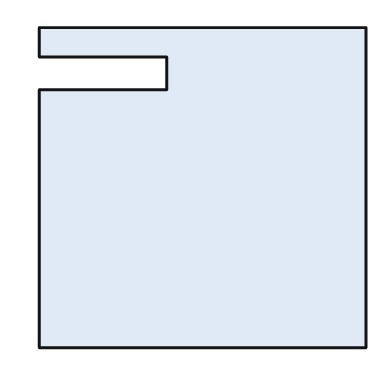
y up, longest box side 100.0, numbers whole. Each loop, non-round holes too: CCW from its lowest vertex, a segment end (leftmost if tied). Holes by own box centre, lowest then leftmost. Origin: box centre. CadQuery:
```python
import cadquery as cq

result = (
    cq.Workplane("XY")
    .moveTo(-50.0, -49.0)
    .lineTo(50.0, -49.0)
    .lineTo(50.0, 49.0)
    .lineTo(-50.0, 49.0)
    .lineTo(-50.0, 40.0)
    .lineTo(-11.0, 40.0)
    .lineTo(-11.0, 30.0)
    .lineTo(-50.0, 30.0)
    .close()
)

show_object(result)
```